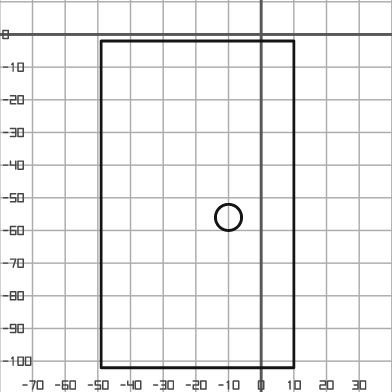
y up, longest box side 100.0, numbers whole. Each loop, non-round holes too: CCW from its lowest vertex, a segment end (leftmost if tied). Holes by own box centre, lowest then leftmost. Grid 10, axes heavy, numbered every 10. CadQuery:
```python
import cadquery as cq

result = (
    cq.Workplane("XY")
    .moveTo(-49.0, -102.0)
    .lineTo(10.0, -102.0)
    .lineTo(10.0, -2.0)
    .lineTo(-49.0, -2.0)
    .close()
    .moveTo(-10.0, -56.0)
    .circle(4.0)
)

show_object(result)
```